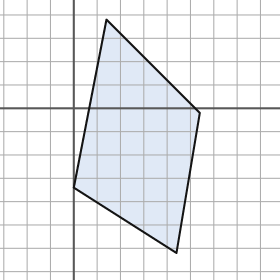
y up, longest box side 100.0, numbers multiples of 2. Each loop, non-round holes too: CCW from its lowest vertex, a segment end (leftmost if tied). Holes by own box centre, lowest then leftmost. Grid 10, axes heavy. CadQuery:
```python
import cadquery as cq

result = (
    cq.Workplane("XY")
    .moveTo(44.0, -62.0)
    .lineTo(54.0, -2.0)
    .lineTo(14.0, 38.0)
    .lineTo(0.0, -34.0)
    .close()
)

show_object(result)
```